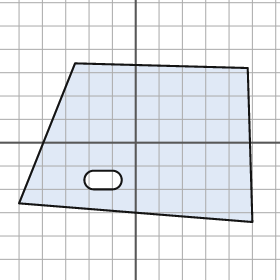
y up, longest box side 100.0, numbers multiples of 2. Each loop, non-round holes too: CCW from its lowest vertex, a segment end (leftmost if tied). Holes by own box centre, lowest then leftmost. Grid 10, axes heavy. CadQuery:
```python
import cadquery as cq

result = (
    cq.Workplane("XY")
    .moveTo(50.0, -34.0)
    .lineTo(48.0, 32.0)
    .lineTo(-26.0, 34.0)
    .lineTo(-50.0, -26.0)
    .close()
    .moveTo(-18.0, -20.0)
    .lineTo(-10.0, -20.0)
    .threePointArc((-6.0, -16.0), (-10.0, -12.0))
    .lineTo(-18.0, -12.0)
    .threePointArc((-22.0, -16.0), (-18.0, -20.0))
    .close()
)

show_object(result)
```